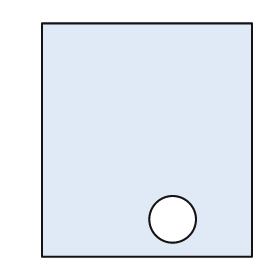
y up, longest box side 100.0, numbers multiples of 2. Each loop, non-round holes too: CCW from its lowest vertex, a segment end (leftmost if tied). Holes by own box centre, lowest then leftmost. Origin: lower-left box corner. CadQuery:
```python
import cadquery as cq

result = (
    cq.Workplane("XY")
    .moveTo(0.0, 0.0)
    .lineTo(90.0, 0.0)
    .lineTo(90.0, 100.0)
    .lineTo(0.0, 100.0)
    .close()
    .moveTo(56.0, 16.0)
    .circle(10.0)
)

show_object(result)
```